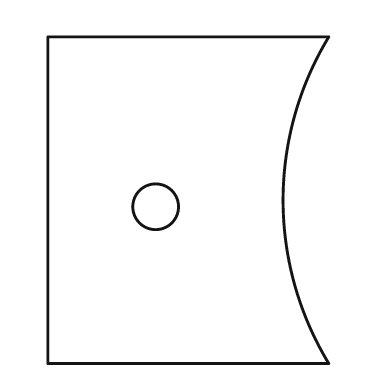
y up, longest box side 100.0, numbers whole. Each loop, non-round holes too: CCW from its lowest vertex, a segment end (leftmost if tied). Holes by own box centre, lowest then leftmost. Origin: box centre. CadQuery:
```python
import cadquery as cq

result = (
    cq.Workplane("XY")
    .moveTo(-43.0, -50.0)
    .lineTo(43.0, -50.0)
    .threePointArc((29.0, 0.0), (43.0, 50.0))
    .lineTo(-43.0, 50.0)
    .close()
    .moveTo(-10.0, -2.0)
    .circle(7.0)
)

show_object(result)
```